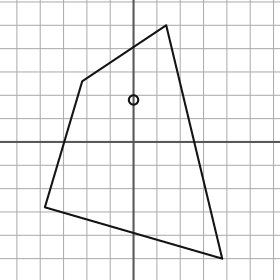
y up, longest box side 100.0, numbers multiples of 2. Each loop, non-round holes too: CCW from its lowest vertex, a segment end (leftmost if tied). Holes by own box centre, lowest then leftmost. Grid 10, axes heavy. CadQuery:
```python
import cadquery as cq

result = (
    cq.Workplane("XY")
    .moveTo(38.0, -50.0)
    .lineTo(14.0, 50.0)
    .lineTo(-22.0, 26.0)
    .lineTo(-38.0, -28.0)
    .close()
    .moveTo(0.0, 18.0)
    .circle(2.0)
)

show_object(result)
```